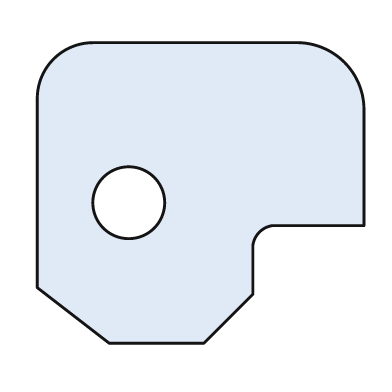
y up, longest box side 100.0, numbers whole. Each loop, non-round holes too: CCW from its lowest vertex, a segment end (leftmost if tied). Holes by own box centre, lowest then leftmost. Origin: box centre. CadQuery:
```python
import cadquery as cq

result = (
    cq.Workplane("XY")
    .moveTo(-28.0, -46.0)
    .lineTo(1.0, -46.0)
    .lineTo(16.0, -31.0)
    .lineTo(16.0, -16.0)
    .threePointArc((18.0, -12.0), (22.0, -10.0))
    .lineTo(50.0, -10.0)
    .lineTo(50.0, 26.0)
    .threePointArc((44.0, 40.0), (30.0, 46.0))
    .lineTo(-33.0, 46.0)
    .threePointArc((-45.0, 41.0), (-50.0, 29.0))
    .lineTo(-50.0, -29.0)
    .close()
    .moveTo(-22.0, -3.0)
    .circle(11.0)
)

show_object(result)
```